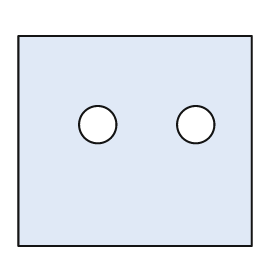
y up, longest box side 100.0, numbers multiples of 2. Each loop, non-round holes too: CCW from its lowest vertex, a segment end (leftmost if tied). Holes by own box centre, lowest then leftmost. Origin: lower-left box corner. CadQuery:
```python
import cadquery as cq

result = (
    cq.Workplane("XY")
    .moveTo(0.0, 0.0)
    .lineTo(100.0, 0.0)
    .lineTo(100.0, 90.0)
    .lineTo(0.0, 90.0)
    .close()
    .moveTo(34.0, 52.0)
    .circle(8.0)
    .moveTo(76.0, 52.0)
    .circle(8.0)
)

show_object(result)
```